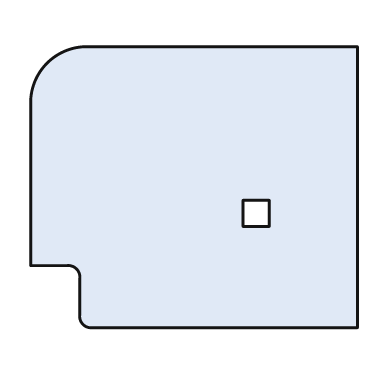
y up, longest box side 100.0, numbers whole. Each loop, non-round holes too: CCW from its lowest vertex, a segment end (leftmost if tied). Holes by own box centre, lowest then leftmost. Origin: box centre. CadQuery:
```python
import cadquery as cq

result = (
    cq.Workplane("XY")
    .moveTo(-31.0, -43.0)
    .lineTo(50.0, -43.0)
    .lineTo(50.0, 43.0)
    .lineTo(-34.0, 43.0)
    .threePointArc((-45.0, 38.0), (-50.0, 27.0))
    .lineTo(-50.0, -24.0)
    .lineTo(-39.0, -24.0)
    .threePointArc((-36.0, -25.0), (-35.0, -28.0))
    .lineTo(-35.0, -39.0)
    .threePointArc((-34.0, -42.0), (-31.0, -43.0))
    .close()
    .moveTo(15.0, -12.0)
    .lineTo(23.0, -12.0)
    .lineTo(23.0, -4.0)
    .lineTo(15.0, -4.0)
    .close()
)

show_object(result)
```